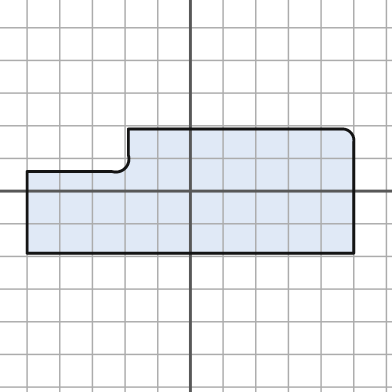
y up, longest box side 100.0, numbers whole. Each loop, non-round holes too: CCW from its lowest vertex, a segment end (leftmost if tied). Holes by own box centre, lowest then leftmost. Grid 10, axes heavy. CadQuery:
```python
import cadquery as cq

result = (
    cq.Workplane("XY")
    .moveTo(-50.0, -19.0)
    .lineTo(50.0, -19.0)
    .lineTo(50.0, 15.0)
    .threePointArc((49.0, 18.0), (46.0, 19.0))
    .lineTo(-19.0, 19.0)
    .lineTo(-19.0, 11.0)
    .threePointArc((-20.0, 7.0), (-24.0, 6.0))
    .lineTo(-50.0, 6.0)
    .close()
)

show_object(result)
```